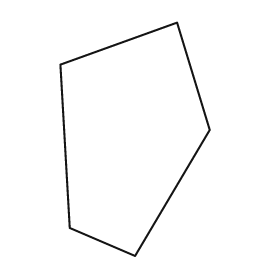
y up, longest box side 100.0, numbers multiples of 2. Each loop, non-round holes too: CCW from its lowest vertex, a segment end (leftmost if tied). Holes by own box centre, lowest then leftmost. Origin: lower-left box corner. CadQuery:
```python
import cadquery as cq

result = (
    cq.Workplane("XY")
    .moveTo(32.0, 0.0)
    .lineTo(64.0, 54.0)
    .lineTo(50.0, 100.0)
    .lineTo(0.0, 82.0)
    .lineTo(4.0, 12.0)
    .close()
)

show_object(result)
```